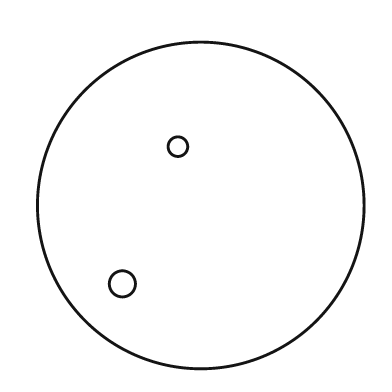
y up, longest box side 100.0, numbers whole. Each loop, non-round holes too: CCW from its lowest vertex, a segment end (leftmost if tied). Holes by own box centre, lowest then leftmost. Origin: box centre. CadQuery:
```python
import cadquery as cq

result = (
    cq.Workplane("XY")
    .moveTo(0.0, 0.0)
    .circle(50.0)
    .moveTo(-24.0, -24.0)
    .circle(4.0)
    .moveTo(-7.0, 18.0)
    .circle(3.0)
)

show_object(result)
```